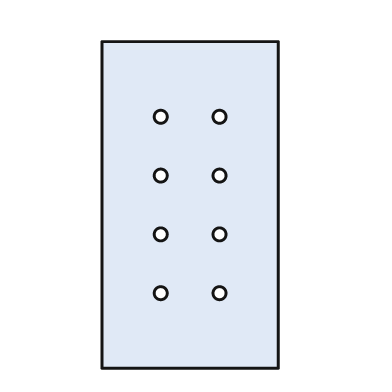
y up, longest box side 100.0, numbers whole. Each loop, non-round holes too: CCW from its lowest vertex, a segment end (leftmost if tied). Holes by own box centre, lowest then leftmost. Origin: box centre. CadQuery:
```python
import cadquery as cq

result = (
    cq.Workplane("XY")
    .moveTo(-27.0, -50.0)
    .lineTo(27.0, -50.0)
    .lineTo(27.0, 50.0)
    .lineTo(-27.0, 50.0)
    .close()
    .moveTo(-9.0, -27.0)
    .circle(2.0)
    .moveTo(9.0, -27.0)
    .circle(2.0)
    .moveTo(-9.0, -9.0)
    .circle(2.0)
    .moveTo(9.0, -9.0)
    .circle(2.0)
    .moveTo(-9.0, 9.0)
    .circle(2.0)
    .moveTo(9.0, 9.0)
    .circle(2.0)
    .moveTo(-9.0, 27.0)
    .circle(2.0)
    .moveTo(9.0, 27.0)
    .circle(2.0)
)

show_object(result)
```